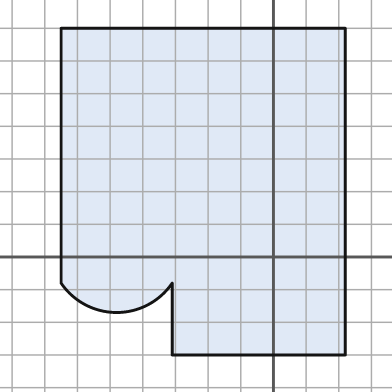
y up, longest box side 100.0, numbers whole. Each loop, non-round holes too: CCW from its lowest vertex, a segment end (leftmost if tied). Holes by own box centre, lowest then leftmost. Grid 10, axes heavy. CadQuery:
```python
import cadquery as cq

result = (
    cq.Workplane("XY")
    .moveTo(-31.0, -30.0)
    .lineTo(22.0, -30.0)
    .lineTo(22.0, 70.0)
    .lineTo(-65.0, 70.0)
    .lineTo(-65.0, -8.0)
    .threePointArc((-48.0, -17.0), (-31.0, -8.0))
    .close()
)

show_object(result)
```